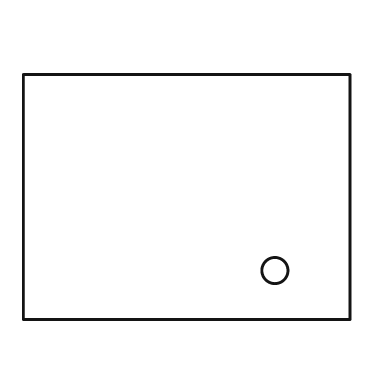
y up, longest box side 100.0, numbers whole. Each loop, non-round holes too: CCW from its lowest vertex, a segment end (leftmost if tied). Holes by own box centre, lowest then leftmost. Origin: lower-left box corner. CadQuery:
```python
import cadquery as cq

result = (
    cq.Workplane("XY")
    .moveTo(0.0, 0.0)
    .lineTo(100.0, 0.0)
    .lineTo(100.0, 75.0)
    .lineTo(0.0, 75.0)
    .close()
    .moveTo(77.0, 15.0)
    .circle(4.0)
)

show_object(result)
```